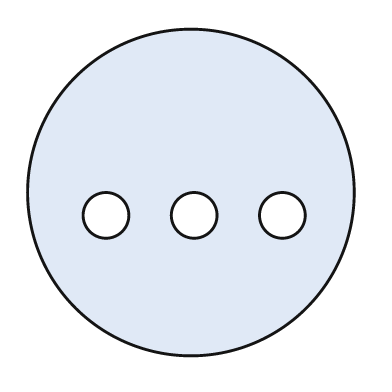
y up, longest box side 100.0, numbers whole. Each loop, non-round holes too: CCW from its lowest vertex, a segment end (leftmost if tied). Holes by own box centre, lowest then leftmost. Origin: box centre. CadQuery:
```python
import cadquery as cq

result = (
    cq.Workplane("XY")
    .moveTo(0.0, 0.0)
    .circle(50.0)
    .moveTo(-26.0, -7.0)
    .circle(7.0)
    .moveTo(1.0, -7.0)
    .circle(7.0)
    .moveTo(28.0, -7.0)
    .circle(7.0)
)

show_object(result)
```